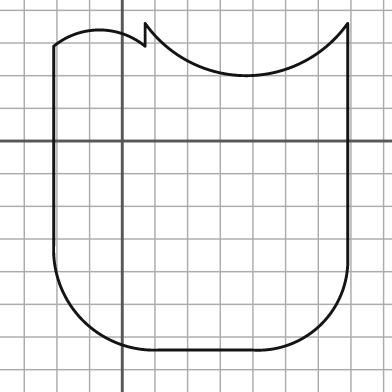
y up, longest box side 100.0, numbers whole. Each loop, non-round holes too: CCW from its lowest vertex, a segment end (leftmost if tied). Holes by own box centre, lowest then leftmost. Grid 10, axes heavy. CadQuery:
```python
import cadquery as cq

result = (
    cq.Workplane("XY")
    .moveTo(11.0, -64.0)
    .lineTo(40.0, -64.0)
    .threePointArc((61.0, -56.0), (69.0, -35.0))
    .lineTo(69.0, 36.0)
    .threePointArc((38.0, 20.0), (7.0, 36.0))
    .lineTo(7.0, 29.0)
    .threePointArc((-7.0, 34.0), (-21.0, 29.0))
    .lineTo(-21.0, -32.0)
    .threePointArc((-12.0, -55.0), (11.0, -64.0))
    .close()
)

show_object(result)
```